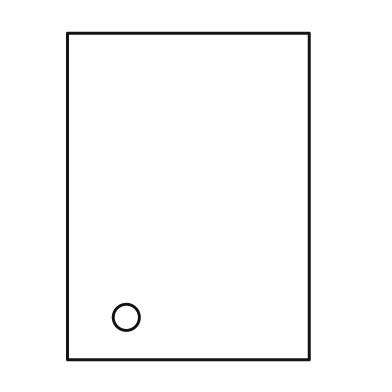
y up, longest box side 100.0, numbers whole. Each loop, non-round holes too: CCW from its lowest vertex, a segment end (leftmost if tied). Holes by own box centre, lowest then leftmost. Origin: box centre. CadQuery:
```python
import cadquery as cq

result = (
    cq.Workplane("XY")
    .moveTo(-37.0, -50.0)
    .lineTo(37.0, -50.0)
    .lineTo(37.0, 50.0)
    .lineTo(-37.0, 50.0)
    .close()
    .moveTo(-19.0, -37.0)
    .circle(4.0)
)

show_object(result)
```